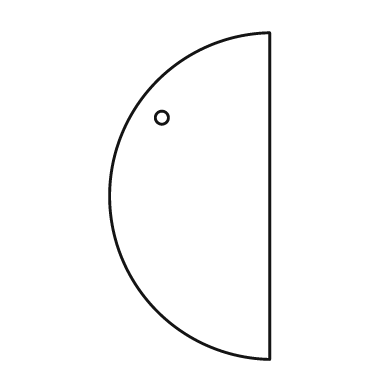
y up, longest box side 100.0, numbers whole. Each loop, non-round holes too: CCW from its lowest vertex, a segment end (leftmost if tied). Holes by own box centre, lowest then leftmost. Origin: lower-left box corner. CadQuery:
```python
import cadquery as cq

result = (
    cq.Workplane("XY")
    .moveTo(49.0, 0.0)
    .lineTo(49.0, 100.0)
    .threePointArc((0.0, 50.0), (49.0, 0.0))
    .close()
    .moveTo(16.0, 74.0)
    .circle(2.0)
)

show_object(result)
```